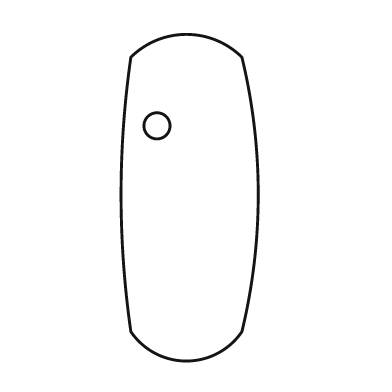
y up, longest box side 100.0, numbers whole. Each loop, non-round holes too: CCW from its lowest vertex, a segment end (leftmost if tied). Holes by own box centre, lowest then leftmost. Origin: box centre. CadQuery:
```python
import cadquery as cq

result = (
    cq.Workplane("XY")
    .moveTo(-18.0, -41.0)
    .threePointArc((-1.0, -50.0), (16.0, -41.0))
    .threePointArc((21.0, 1.0), (16.0, 43.0))
    .threePointArc((-1.0, 50.0), (-18.0, 43.0))
    .threePointArc((-21.0, 1.0), (-18.0, -41.0))
    .close()
    .moveTo(-10.0, 22.0)
    .circle(4.0)
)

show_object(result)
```